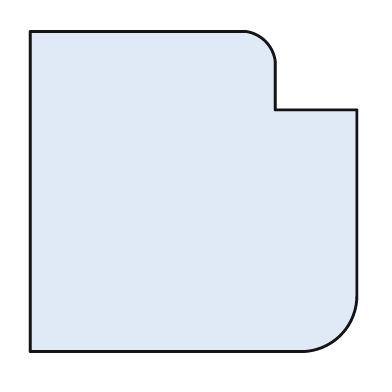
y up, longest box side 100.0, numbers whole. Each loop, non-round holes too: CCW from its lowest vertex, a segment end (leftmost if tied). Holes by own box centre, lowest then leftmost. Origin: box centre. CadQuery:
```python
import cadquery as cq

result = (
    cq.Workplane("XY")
    .moveTo(-50.0, -49.0)
    .lineTo(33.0, -49.0)
    .threePointArc((45.0, -44.0), (50.0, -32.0))
    .lineTo(50.0, 25.0)
    .lineTo(25.0, 25.0)
    .lineTo(25.0, 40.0)
    .threePointArc((22.0, 46.0), (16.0, 49.0))
    .lineTo(-50.0, 49.0)
    .close()
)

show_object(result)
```